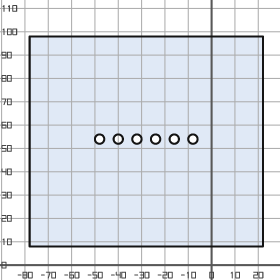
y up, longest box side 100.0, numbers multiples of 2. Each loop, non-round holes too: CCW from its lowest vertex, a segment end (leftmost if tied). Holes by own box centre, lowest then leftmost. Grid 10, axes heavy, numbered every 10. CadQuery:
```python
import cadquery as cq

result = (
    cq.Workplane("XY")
    .moveTo(-78.0, 8.0)
    .lineTo(22.0, 8.0)
    .lineTo(22.0, 98.0)
    .lineTo(-78.0, 98.0)
    .close()
    .moveTo(-48.0, 54.0)
    .circle(2.0)
    .moveTo(-40.0, 54.0)
    .circle(2.0)
    .moveTo(-32.0, 54.0)
    .circle(2.0)
    .moveTo(-24.0, 54.0)
    .circle(2.0)
    .moveTo(-16.0, 54.0)
    .circle(2.0)
    .moveTo(-8.0, 54.0)
    .circle(2.0)
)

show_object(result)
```